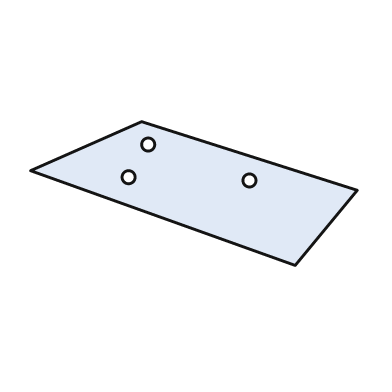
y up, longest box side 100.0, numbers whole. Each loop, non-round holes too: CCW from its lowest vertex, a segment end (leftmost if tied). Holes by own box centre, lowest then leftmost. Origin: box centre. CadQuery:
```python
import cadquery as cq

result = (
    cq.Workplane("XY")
    .moveTo(31.0, -22.0)
    .lineTo(50.0, 1.0)
    .lineTo(-16.0, 22.0)
    .lineTo(-50.0, 7.0)
    .close()
    .moveTo(17.0, 4.0)
    .circle(2.0)
    .moveTo(-20.0, 5.0)
    .circle(2.0)
    .moveTo(-14.0, 15.0)
    .circle(2.0)
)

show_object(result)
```